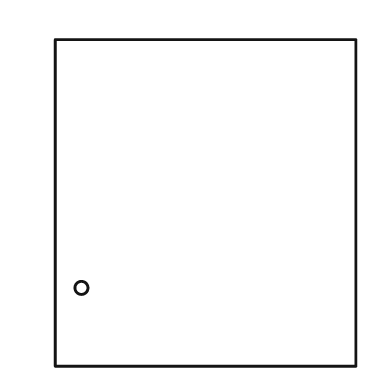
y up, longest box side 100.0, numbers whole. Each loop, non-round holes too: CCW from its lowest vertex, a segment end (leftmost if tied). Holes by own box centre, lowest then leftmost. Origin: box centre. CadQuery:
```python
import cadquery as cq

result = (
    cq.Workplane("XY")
    .moveTo(-46.0, -50.0)
    .lineTo(46.0, -50.0)
    .lineTo(46.0, 50.0)
    .lineTo(-46.0, 50.0)
    .close()
    .moveTo(-38.0, -26.0)
    .circle(2.0)
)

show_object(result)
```